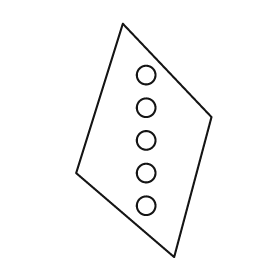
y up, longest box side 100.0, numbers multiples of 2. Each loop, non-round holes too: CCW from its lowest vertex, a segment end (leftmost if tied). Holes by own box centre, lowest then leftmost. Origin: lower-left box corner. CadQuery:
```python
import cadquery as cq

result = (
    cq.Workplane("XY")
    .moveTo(42.0, 0.0)
    .lineTo(58.0, 60.0)
    .lineTo(20.0, 100.0)
    .lineTo(0.0, 36.0)
    .close()
    .moveTo(30.0, 22.0)
    .circle(4.0)
    .moveTo(30.0, 36.0)
    .circle(4.0)
    .moveTo(30.0, 50.0)
    .circle(4.0)
    .moveTo(30.0, 64.0)
    .circle(4.0)
    .moveTo(30.0, 78.0)
    .circle(4.0)
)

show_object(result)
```